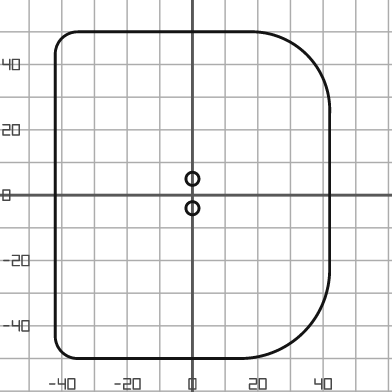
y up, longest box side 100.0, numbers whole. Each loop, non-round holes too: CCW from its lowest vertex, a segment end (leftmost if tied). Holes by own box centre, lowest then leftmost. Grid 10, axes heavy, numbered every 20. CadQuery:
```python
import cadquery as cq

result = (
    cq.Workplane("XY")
    .moveTo(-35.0, -50.0)
    .lineTo(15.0, -50.0)
    .threePointArc((34.0, -42.0), (42.0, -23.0))
    .lineTo(42.0, 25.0)
    .threePointArc((35.0, 43.0), (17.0, 50.0))
    .lineTo(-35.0, 50.0)
    .threePointArc((-40.0, 48.0), (-42.0, 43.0))
    .lineTo(-42.0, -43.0)
    .threePointArc((-40.0, -48.0), (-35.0, -50.0))
    .close()
    .moveTo(0.0, -4.0)
    .circle(2.0)
    .moveTo(0.0, 5.0)
    .circle(2.0)
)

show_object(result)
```